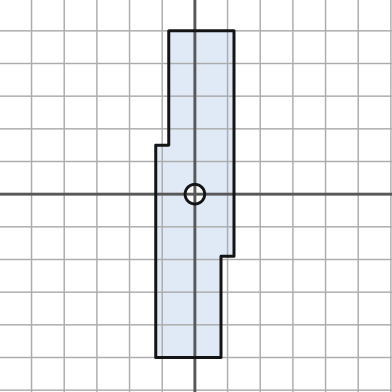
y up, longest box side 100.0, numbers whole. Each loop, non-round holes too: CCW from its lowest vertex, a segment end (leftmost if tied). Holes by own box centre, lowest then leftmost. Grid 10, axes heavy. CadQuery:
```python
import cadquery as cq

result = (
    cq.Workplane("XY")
    .moveTo(-12.0, -50.0)
    .lineTo(8.0, -50.0)
    .lineTo(8.0, -19.0)
    .lineTo(12.0, -19.0)
    .lineTo(12.0, 50.0)
    .lineTo(-8.0, 50.0)
    .lineTo(-8.0, 15.0)
    .lineTo(-12.0, 15.0)
    .close()
    .moveTo(0.0, 0.0)
    .circle(3.0)
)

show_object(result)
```